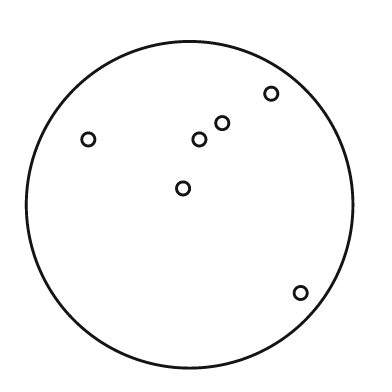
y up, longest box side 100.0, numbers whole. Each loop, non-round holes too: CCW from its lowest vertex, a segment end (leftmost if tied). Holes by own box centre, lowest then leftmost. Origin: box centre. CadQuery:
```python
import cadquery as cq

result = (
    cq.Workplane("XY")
    .moveTo(0.0, 0.0)
    .circle(50.0)
    .moveTo(34.0, -27.0)
    .circle(2.0)
    .moveTo(-2.0, 5.0)
    .circle(2.0)
    .moveTo(-31.0, 20.0)
    .circle(2.0)
    .moveTo(3.0, 20.0)
    .circle(2.0)
    .moveTo(10.0, 25.0)
    .circle(2.0)
    .moveTo(25.0, 34.0)
    .circle(2.0)
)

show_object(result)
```